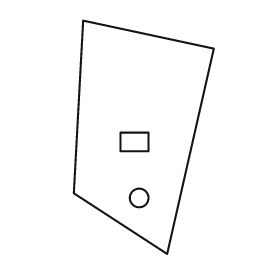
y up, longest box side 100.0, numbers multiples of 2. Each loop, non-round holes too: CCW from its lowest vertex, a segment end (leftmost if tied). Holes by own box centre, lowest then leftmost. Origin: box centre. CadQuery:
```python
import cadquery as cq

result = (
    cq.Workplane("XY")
    .moveTo(10.0, -50.0)
    .lineTo(30.0, 38.0)
    .lineTo(-26.0, 50.0)
    .lineTo(-30.0, -24.0)
    .close()
    .moveTo(-2.0, -26.0)
    .circle(4.0)
    .moveTo(-10.0, -6.0)
    .lineTo(2.0, -6.0)
    .lineTo(2.0, 2.0)
    .lineTo(-10.0, 2.0)
    .close()
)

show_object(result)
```